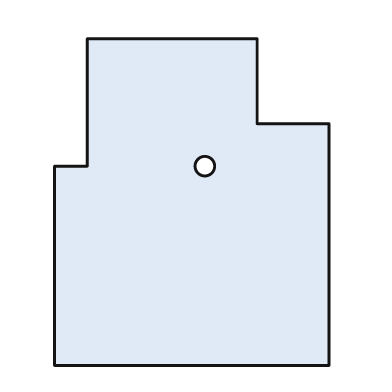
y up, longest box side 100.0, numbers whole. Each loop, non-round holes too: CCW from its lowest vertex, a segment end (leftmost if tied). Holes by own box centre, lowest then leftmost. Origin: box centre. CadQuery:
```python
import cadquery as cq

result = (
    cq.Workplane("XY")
    .moveTo(-42.0, -50.0)
    .lineTo(42.0, -50.0)
    .lineTo(42.0, 24.0)
    .lineTo(20.0, 24.0)
    .lineTo(20.0, 50.0)
    .lineTo(-32.0, 50.0)
    .lineTo(-32.0, 11.0)
    .lineTo(-42.0, 11.0)
    .close()
    .moveTo(4.0, 11.0)
    .circle(3.0)
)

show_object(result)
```